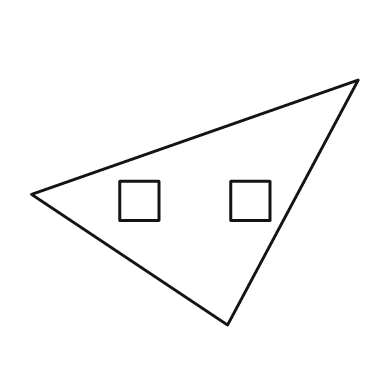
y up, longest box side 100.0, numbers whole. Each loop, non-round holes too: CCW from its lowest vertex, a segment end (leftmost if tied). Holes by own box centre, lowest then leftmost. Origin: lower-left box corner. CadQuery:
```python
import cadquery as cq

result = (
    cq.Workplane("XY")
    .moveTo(60.0, 0.0)
    .lineTo(100.0, 75.0)
    .lineTo(0.0, 40.0)
    .close()
    .moveTo(27.0, 32.0)
    .lineTo(39.0, 32.0)
    .lineTo(39.0, 44.0)
    .lineTo(27.0, 44.0)
    .close()
    .moveTo(61.0, 32.0)
    .lineTo(73.0, 32.0)
    .lineTo(73.0, 44.0)
    .lineTo(61.0, 44.0)
    .close()
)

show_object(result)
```